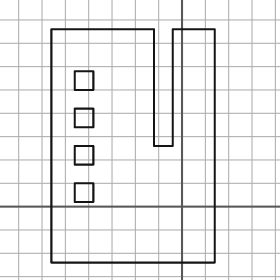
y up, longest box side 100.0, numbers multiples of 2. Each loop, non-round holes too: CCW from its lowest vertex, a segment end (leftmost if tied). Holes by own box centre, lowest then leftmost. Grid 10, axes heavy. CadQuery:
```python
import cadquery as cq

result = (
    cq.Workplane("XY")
    .moveTo(-56.0, -24.0)
    .lineTo(14.0, -24.0)
    .lineTo(14.0, 76.0)
    .lineTo(-4.0, 76.0)
    .lineTo(-4.0, 26.0)
    .lineTo(-12.0, 26.0)
    .lineTo(-12.0, 76.0)
    .lineTo(-56.0, 76.0)
    .close()
    .moveTo(-46.0, 2.0)
    .lineTo(-38.0, 2.0)
    .lineTo(-38.0, 10.0)
    .lineTo(-46.0, 10.0)
    .close()
    .moveTo(-46.0, 18.0)
    .lineTo(-38.0, 18.0)
    .lineTo(-38.0, 26.0)
    .lineTo(-46.0, 26.0)
    .close()
    .moveTo(-46.0, 34.0)
    .lineTo(-38.0, 34.0)
    .lineTo(-38.0, 42.0)
    .lineTo(-46.0, 42.0)
    .close()
    .moveTo(-46.0, 50.0)
    .lineTo(-38.0, 50.0)
    .lineTo(-38.0, 58.0)
    .lineTo(-46.0, 58.0)
    .close()
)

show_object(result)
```